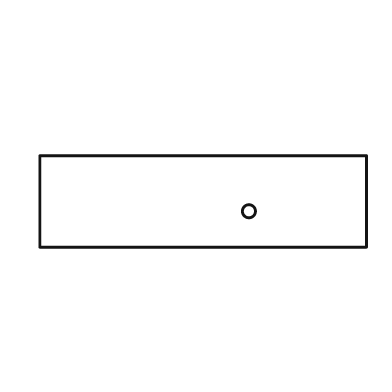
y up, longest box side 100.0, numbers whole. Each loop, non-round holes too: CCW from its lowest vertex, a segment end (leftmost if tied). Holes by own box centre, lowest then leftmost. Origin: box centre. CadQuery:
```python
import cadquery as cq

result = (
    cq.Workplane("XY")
    .moveTo(-50.0, -14.0)
    .lineTo(50.0, -14.0)
    .lineTo(50.0, 14.0)
    .lineTo(-50.0, 14.0)
    .close()
    .moveTo(14.0, -3.0)
    .circle(2.0)
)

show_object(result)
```